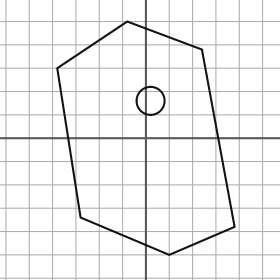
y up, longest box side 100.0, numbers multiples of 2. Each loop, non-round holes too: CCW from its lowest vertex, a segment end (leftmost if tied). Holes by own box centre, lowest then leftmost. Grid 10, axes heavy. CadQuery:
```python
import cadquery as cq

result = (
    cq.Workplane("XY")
    .moveTo(10.0, -50.0)
    .lineTo(38.0, -38.0)
    .lineTo(24.0, 38.0)
    .lineTo(-8.0, 50.0)
    .lineTo(-38.0, 30.0)
    .lineTo(-28.0, -34.0)
    .close()
    .moveTo(2.0, 16.0)
    .circle(6.0)
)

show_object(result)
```